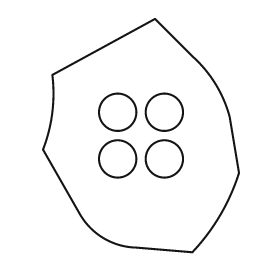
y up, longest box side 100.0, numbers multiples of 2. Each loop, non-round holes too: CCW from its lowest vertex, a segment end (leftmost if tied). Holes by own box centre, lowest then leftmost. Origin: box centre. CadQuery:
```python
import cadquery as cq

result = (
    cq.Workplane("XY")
    .moveTo(22.0, -50.0)
    .threePointArc((34.0, -34.0), (42.0, -16.0))
    .lineTo(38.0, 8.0)
    .threePointArc((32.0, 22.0), (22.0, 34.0))
    .lineTo(6.0, 50.0)
    .lineTo(-38.0, 26.0)
    .threePointArc((-38.0, 10.0), (-42.0, -6.0))
    .lineTo(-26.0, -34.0)
    .threePointArc((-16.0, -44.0), (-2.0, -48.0))
    .close()
    .moveTo(-10.0, -10.0)
    .circle(8.0)
    .moveTo(10.0, -10.0)
    .circle(8.0)
    .moveTo(-10.0, 10.0)
    .circle(8.0)
    .moveTo(10.0, 10.0)
    .circle(8.0)
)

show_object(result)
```